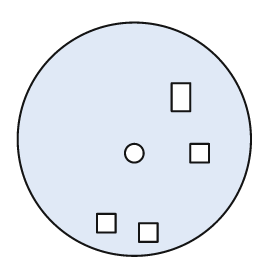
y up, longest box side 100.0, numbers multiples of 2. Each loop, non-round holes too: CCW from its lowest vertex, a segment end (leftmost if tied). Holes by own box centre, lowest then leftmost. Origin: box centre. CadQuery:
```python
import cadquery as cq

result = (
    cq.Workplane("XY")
    .moveTo(0.0, 0.0)
    .circle(50.0)
    .moveTo(2.0, -44.0)
    .lineTo(10.0, -44.0)
    .lineTo(10.0, -36.0)
    .lineTo(2.0, -36.0)
    .close()
    .moveTo(-16.0, -40.0)
    .lineTo(-8.0, -40.0)
    .lineTo(-8.0, -32.0)
    .lineTo(-16.0, -32.0)
    .close()
    .moveTo(0.0, -6.0)
    .circle(4.0)
    .moveTo(24.0, -10.0)
    .lineTo(32.0, -10.0)
    .lineTo(32.0, -2.0)
    .lineTo(24.0, -2.0)
    .close()
    .moveTo(16.0, 12.0)
    .lineTo(24.0, 12.0)
    .lineTo(24.0, 24.0)
    .lineTo(16.0, 24.0)
    .close()
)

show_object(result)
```